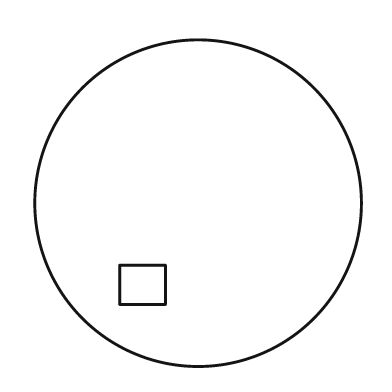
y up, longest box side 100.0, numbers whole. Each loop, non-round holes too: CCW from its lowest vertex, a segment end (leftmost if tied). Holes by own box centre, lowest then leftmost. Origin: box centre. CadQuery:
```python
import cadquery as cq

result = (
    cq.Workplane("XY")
    .moveTo(0.0, 0.0)
    .circle(50.0)
    .moveTo(-24.0, -31.0)
    .lineTo(-10.0, -31.0)
    .lineTo(-10.0, -19.0)
    .lineTo(-24.0, -19.0)
    .close()
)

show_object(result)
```